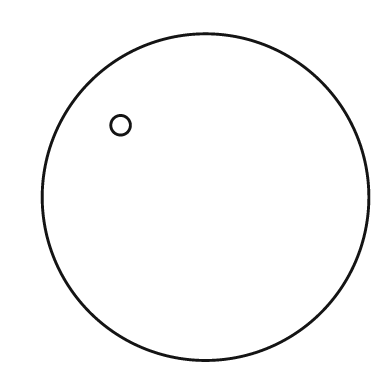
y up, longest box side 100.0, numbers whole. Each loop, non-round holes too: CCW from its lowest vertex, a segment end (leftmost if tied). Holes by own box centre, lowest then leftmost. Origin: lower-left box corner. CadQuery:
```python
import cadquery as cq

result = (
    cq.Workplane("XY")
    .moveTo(50.0, 50.0)
    .circle(50.0)
    .moveTo(24.0, 72.0)
    .circle(3.0)
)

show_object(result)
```